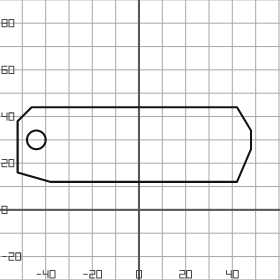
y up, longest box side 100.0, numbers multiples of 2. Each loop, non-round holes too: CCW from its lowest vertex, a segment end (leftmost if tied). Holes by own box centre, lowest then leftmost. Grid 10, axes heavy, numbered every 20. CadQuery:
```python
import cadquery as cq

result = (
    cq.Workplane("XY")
    .moveTo(-38.0, 12.0)
    .lineTo(42.0, 12.0)
    .lineTo(48.0, 26.0)
    .lineTo(48.0, 34.0)
    .lineTo(42.0, 44.0)
    .lineTo(-46.0, 44.0)
    .lineTo(-52.0, 38.0)
    .lineTo(-52.0, 16.0)
    .close()
    .moveTo(-44.0, 30.0)
    .circle(4.0)
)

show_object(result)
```